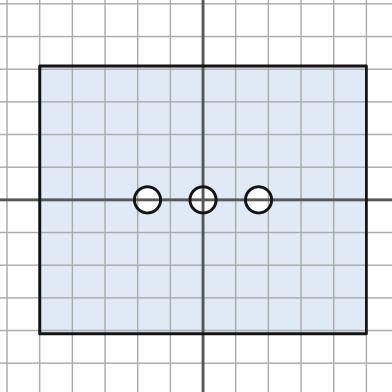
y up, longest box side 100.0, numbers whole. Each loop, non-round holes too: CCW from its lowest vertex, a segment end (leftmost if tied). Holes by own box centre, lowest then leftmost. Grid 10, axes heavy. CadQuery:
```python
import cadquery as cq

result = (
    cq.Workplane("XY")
    .moveTo(-50.0, -41.0)
    .lineTo(50.0, -41.0)
    .lineTo(50.0, 41.0)
    .lineTo(-50.0, 41.0)
    .close()
    .moveTo(-17.0, 0.0)
    .circle(4.0)
    .moveTo(0.0, 0.0)
    .circle(4.0)
    .moveTo(17.0, 0.0)
    .circle(4.0)
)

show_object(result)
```